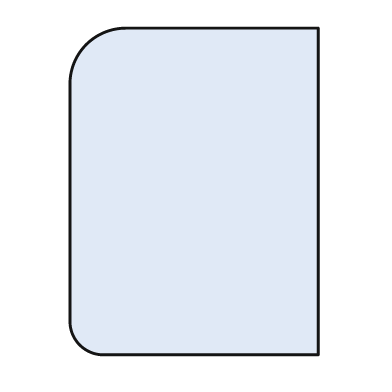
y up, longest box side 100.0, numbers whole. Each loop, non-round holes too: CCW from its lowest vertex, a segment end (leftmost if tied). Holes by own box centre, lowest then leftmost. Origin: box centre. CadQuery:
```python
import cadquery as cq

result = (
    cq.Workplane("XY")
    .moveTo(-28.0, -50.0)
    .lineTo(38.0, -50.0)
    .lineTo(38.0, 50.0)
    .lineTo(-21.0, 50.0)
    .threePointArc((-33.0, 45.0), (-38.0, 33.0))
    .lineTo(-38.0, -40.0)
    .threePointArc((-35.0, -47.0), (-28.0, -50.0))
    .close()
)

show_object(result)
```